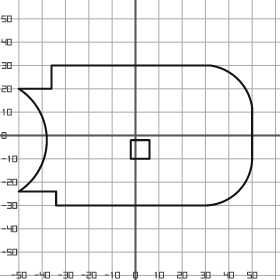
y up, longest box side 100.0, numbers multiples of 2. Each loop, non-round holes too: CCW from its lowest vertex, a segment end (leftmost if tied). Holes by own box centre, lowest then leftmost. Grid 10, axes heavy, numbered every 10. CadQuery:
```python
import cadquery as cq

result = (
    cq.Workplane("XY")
    .moveTo(-34.0, -30.0)
    .lineTo(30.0, -30.0)
    .threePointArc((44.0, -24.0), (50.0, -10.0))
    .lineTo(50.0, 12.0)
    .threePointArc((44.0, 24.0), (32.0, 30.0))
    .lineTo(-36.0, 30.0)
    .lineTo(-36.0, 20.0)
    .lineTo(-50.0, 20.0)
    .threePointArc((-38.0, -2.0), (-50.0, -24.0))
    .lineTo(-34.0, -24.0)
    .close()
    .moveTo(-2.0, -10.0)
    .lineTo(6.0, -10.0)
    .lineTo(6.0, -2.0)
    .lineTo(-2.0, -2.0)
    .close()
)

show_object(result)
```